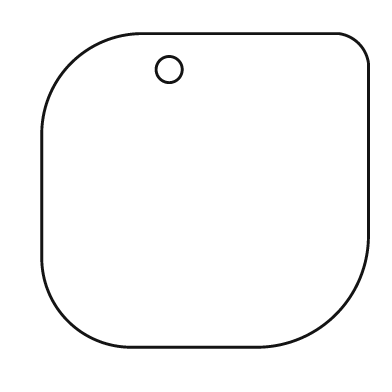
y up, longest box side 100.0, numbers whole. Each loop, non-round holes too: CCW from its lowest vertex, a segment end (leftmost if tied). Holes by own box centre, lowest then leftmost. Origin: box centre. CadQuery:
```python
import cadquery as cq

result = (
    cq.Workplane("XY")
    .moveTo(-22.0, -48.0)
    .lineTo(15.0, -48.0)
    .threePointArc((40.0, -38.0), (50.0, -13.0))
    .lineTo(50.0, 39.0)
    .threePointArc((47.0, 45.0), (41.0, 48.0))
    .lineTo(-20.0, 48.0)
    .threePointArc((-41.0, 39.0), (-50.0, 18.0))
    .lineTo(-50.0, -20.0)
    .threePointArc((-42.0, -40.0), (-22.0, -48.0))
    .close()
    .moveTo(-11.0, 37.0)
    .circle(4.0)
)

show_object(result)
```